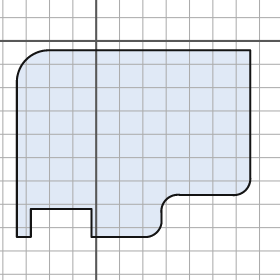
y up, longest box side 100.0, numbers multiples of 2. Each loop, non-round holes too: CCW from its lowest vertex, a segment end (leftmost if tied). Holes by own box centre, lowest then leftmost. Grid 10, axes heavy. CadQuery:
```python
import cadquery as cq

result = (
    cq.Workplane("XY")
    .moveTo(-34.0, -84.0)
    .lineTo(-28.0, -84.0)
    .lineTo(-28.0, -72.0)
    .lineTo(-2.0, -72.0)
    .lineTo(-2.0, -84.0)
    .lineTo(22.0, -84.0)
    .threePointArc((26.0, -82.0), (28.0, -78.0))
    .lineTo(28.0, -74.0)
    .threePointArc((30.0, -68.0), (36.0, -66.0))
    .lineTo(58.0, -66.0)
    .threePointArc((64.0, -64.0), (66.0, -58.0))
    .lineTo(66.0, -4.0)
    .lineTo(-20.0, -4.0)
    .threePointArc((-30.0, -8.0), (-34.0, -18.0))
    .close()
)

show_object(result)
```